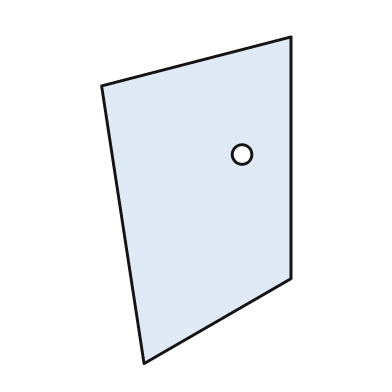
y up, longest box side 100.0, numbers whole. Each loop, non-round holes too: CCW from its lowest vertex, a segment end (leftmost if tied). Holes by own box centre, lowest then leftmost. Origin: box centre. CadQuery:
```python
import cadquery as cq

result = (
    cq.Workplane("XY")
    .moveTo(-16.0, -50.0)
    .lineTo(29.0, -24.0)
    .lineTo(29.0, 50.0)
    .lineTo(-29.0, 35.0)
    .close()
    .moveTo(14.0, 14.0)
    .circle(3.0)
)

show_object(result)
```